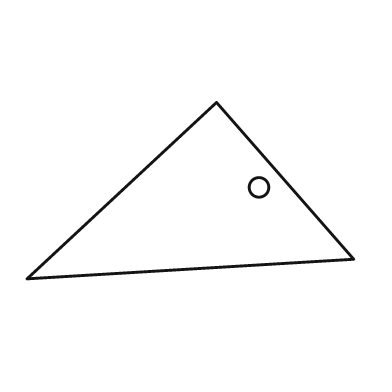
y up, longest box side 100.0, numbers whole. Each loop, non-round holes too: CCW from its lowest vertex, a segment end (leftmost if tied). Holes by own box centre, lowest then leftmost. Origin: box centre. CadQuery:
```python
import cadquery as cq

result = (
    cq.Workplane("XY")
    .moveTo(-50.0, -27.0)
    .lineTo(50.0, -21.0)
    .lineTo(8.0, 27.0)
    .close()
    .moveTo(21.0, 1.0)
    .circle(3.0)
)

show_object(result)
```